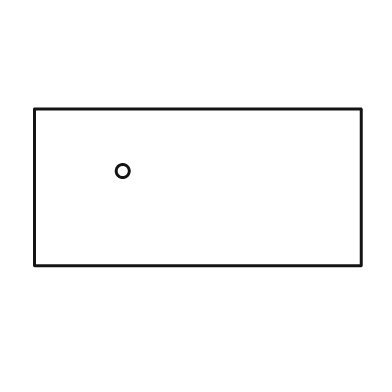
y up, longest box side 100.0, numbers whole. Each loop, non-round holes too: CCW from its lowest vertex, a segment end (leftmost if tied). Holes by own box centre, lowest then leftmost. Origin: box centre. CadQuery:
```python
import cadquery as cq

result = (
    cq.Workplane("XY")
    .moveTo(-50.0, -24.0)
    .lineTo(50.0, -24.0)
    .lineTo(50.0, 24.0)
    .lineTo(-50.0, 24.0)
    .close()
    .moveTo(-23.0, 5.0)
    .circle(2.0)
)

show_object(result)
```